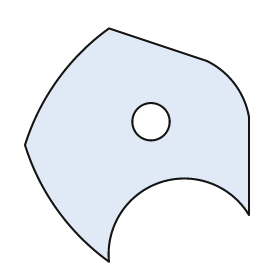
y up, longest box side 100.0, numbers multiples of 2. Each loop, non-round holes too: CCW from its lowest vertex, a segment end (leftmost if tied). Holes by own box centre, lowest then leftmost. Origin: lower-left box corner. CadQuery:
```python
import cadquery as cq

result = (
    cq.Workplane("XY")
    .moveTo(36.0, 0.0)
    .threePointArc((58.0, 34.0), (96.0, 20.0))
    .lineTo(96.0, 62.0)
    .threePointArc((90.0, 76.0), (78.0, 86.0))
    .lineTo(36.0, 100.0)
    .threePointArc((14.0, 78.0), (0.0, 50.0))
    .threePointArc((14.0, 22.0), (36.0, 0.0))
    .close()
    .moveTo(54.0, 60.0)
    .circle(8.0)
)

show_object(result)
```